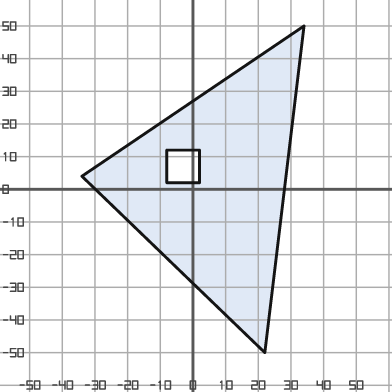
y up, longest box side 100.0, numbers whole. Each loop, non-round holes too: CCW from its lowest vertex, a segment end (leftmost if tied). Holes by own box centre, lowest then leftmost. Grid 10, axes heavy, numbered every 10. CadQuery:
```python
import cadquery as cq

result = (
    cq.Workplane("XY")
    .moveTo(22.0, -50.0)
    .lineTo(34.0, 50.0)
    .lineTo(-34.0, 4.0)
    .close()
    .moveTo(-8.0, 2.0)
    .lineTo(2.0, 2.0)
    .lineTo(2.0, 12.0)
    .lineTo(-8.0, 12.0)
    .close()
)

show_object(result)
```